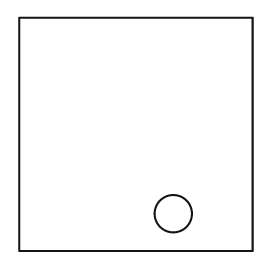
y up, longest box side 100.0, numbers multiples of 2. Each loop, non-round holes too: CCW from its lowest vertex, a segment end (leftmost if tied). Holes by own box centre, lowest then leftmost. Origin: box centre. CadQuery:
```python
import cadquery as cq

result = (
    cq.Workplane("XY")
    .moveTo(-50.0, -50.0)
    .lineTo(50.0, -50.0)
    .lineTo(50.0, 50.0)
    .lineTo(-50.0, 50.0)
    .close()
    .moveTo(16.0, -34.0)
    .circle(8.0)
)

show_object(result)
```